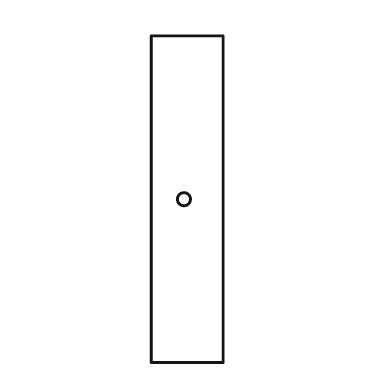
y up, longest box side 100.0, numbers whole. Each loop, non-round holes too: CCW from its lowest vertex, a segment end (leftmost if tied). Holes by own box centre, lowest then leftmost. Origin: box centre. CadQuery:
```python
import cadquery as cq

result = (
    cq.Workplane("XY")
    .moveTo(-11.0, -50.0)
    .lineTo(11.0, -50.0)
    .lineTo(11.0, 50.0)
    .lineTo(-11.0, 50.0)
    .close()
    .moveTo(-1.0, 0.0)
    .circle(2.0)
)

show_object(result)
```